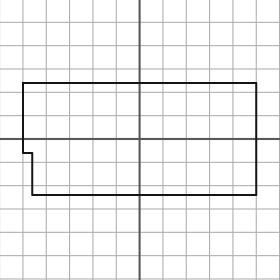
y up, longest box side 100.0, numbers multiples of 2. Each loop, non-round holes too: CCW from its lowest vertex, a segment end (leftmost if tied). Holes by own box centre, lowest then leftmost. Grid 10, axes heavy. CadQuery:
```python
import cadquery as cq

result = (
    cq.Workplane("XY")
    .moveTo(-46.0, -24.0)
    .lineTo(50.0, -24.0)
    .lineTo(50.0, 24.0)
    .lineTo(-50.0, 24.0)
    .lineTo(-50.0, -6.0)
    .lineTo(-46.0, -6.0)
    .close()
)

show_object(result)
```